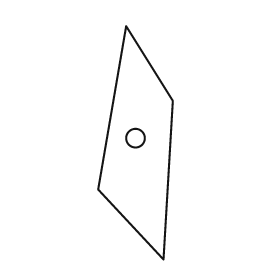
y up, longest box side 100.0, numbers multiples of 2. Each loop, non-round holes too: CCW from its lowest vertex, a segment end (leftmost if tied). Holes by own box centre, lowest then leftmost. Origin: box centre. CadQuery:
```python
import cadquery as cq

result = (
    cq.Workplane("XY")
    .moveTo(12.0, -50.0)
    .lineTo(16.0, 18.0)
    .lineTo(-4.0, 50.0)
    .lineTo(-16.0, -20.0)
    .close()
    .moveTo(0.0, 2.0)
    .circle(4.0)
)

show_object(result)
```